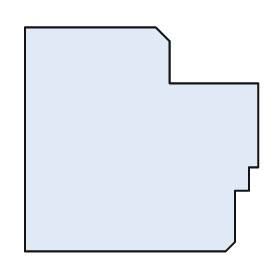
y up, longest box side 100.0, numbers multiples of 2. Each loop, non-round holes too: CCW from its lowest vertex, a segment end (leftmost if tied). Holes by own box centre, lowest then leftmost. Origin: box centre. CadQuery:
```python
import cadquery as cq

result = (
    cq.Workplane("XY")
    .moveTo(-50.0, -48.0)
    .lineTo(36.0, -48.0)
    .lineTo(40.0, -44.0)
    .lineTo(40.0, -22.0)
    .lineTo(46.0, -22.0)
    .lineTo(46.0, -12.0)
    .lineTo(50.0, -12.0)
    .lineTo(50.0, 24.0)
    .lineTo(12.0, 24.0)
    .lineTo(12.0, 42.0)
    .lineTo(6.0, 48.0)
    .lineTo(-50.0, 48.0)
    .close()
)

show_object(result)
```